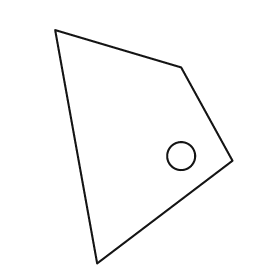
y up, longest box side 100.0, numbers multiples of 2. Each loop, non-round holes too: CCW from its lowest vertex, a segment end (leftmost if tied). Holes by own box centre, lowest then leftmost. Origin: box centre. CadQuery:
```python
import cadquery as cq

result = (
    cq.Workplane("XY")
    .moveTo(-20.0, -50.0)
    .lineTo(38.0, -6.0)
    .lineTo(16.0, 34.0)
    .lineTo(-38.0, 50.0)
    .close()
    .moveTo(16.0, -4.0)
    .circle(6.0)
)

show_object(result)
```